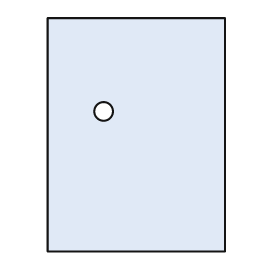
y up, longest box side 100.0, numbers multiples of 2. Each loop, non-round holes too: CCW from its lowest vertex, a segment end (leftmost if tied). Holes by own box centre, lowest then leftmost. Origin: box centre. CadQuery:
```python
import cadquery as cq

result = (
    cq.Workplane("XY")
    .moveTo(-38.0, -50.0)
    .lineTo(38.0, -50.0)
    .lineTo(38.0, 50.0)
    .lineTo(-38.0, 50.0)
    .close()
    .moveTo(-14.0, 10.0)
    .circle(4.0)
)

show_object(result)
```